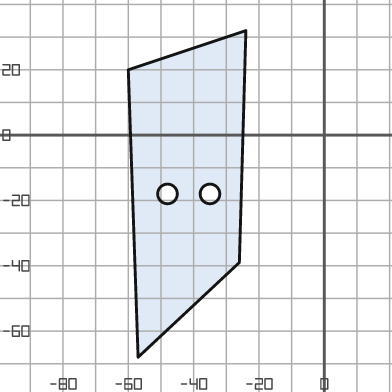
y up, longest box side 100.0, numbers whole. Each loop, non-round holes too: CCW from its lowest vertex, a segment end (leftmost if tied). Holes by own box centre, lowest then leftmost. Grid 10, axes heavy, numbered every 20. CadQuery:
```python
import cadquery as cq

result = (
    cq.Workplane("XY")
    .moveTo(-57.0, -68.0)
    .lineTo(-26.0, -39.0)
    .lineTo(-24.0, 32.0)
    .lineTo(-60.0, 20.0)
    .close()
    .moveTo(-48.0, -18.0)
    .circle(3.0)
    .moveTo(-35.0, -18.0)
    .circle(3.0)
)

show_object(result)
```